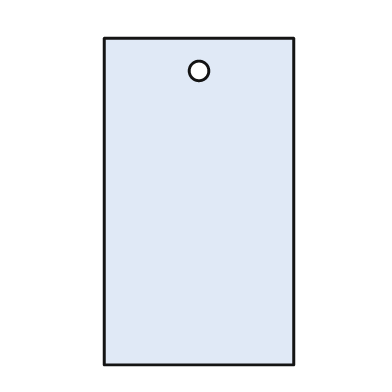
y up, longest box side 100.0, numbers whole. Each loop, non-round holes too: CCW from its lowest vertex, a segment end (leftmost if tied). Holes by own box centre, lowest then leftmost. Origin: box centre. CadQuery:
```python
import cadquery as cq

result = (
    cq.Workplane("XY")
    .moveTo(-29.0, -50.0)
    .lineTo(29.0, -50.0)
    .lineTo(29.0, 50.0)
    .lineTo(-29.0, 50.0)
    .close()
    .moveTo(0.0, 40.0)
    .circle(3.0)
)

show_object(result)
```